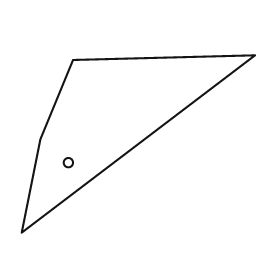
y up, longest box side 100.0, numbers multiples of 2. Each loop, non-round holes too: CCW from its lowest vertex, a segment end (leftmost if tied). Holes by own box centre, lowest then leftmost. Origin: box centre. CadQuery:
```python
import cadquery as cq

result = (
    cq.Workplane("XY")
    .moveTo(-50.0, -38.0)
    .lineTo(50.0, 38.0)
    .lineTo(-28.0, 36.0)
    .lineTo(-42.0, 2.0)
    .close()
    .moveTo(-30.0, -8.0)
    .circle(2.0)
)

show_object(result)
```